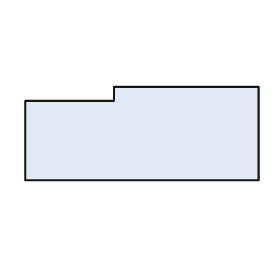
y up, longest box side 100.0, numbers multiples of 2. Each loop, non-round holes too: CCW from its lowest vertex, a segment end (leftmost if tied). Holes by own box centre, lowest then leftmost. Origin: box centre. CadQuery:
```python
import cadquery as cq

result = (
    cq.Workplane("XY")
    .moveTo(-50.0, -20.0)
    .lineTo(50.0, -20.0)
    .lineTo(50.0, 20.0)
    .lineTo(-12.0, 20.0)
    .lineTo(-12.0, 14.0)
    .lineTo(-50.0, 14.0)
    .close()
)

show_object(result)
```